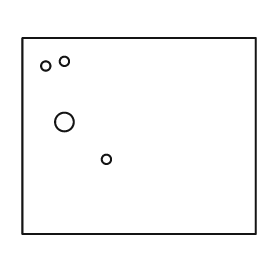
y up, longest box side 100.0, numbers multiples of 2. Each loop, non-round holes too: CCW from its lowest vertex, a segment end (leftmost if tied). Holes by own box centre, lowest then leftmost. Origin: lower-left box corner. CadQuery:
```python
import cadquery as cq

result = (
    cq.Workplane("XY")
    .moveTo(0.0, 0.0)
    .lineTo(100.0, 0.0)
    .lineTo(100.0, 84.0)
    .lineTo(0.0, 84.0)
    .close()
    .moveTo(36.0, 32.0)
    .circle(2.0)
    .moveTo(18.0, 48.0)
    .circle(4.0)
    .moveTo(10.0, 72.0)
    .circle(2.0)
    .moveTo(18.0, 74.0)
    .circle(2.0)
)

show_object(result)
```